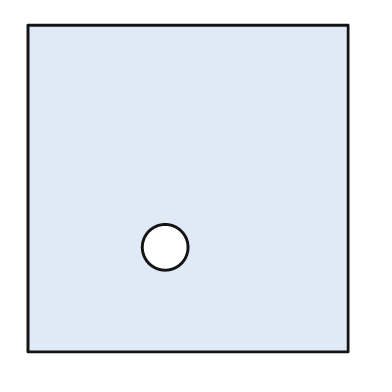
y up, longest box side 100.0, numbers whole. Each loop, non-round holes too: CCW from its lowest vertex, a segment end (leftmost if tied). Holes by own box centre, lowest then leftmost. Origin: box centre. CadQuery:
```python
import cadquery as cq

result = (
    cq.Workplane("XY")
    .moveTo(-49.0, -50.0)
    .lineTo(49.0, -50.0)
    .lineTo(49.0, 50.0)
    .lineTo(-49.0, 50.0)
    .close()
    .moveTo(-7.0, -18.0)
    .circle(7.0)
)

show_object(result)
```